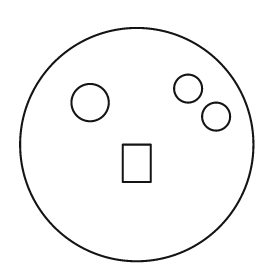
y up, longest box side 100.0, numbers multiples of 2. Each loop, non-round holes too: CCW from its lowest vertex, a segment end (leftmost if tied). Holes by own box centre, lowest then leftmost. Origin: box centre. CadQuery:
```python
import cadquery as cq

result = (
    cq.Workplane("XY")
    .moveTo(0.0, 0.0)
    .circle(50.0)
    .moveTo(-6.0, -16.0)
    .lineTo(6.0, -16.0)
    .lineTo(6.0, 0.0)
    .lineTo(-6.0, 0.0)
    .close()
    .moveTo(34.0, 12.0)
    .circle(6.0)
    .moveTo(-20.0, 18.0)
    .circle(8.0)
    .moveTo(22.0, 24.0)
    .circle(6.0)
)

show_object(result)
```